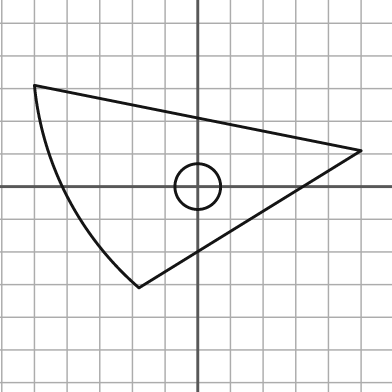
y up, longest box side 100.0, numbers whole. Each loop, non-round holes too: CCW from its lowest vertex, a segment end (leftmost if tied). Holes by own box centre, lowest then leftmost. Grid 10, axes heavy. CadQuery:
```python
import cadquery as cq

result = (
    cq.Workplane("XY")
    .moveTo(-18.0, -31.0)
    .lineTo(50.0, 11.0)
    .lineTo(-50.0, 31.0)
    .threePointArc((-40.0, -3.0), (-18.0, -31.0))
    .close()
    .moveTo(0.0, 0.0)
    .circle(7.0)
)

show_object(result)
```